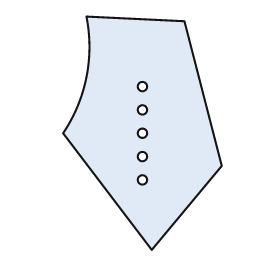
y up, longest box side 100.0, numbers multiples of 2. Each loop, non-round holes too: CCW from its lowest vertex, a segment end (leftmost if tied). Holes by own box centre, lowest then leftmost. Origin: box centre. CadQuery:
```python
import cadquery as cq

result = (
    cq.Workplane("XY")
    .moveTo(4.0, -50.0)
    .lineTo(34.0, -14.0)
    .lineTo(18.0, 48.0)
    .lineTo(-24.0, 50.0)
    .threePointArc((-24.0, 24.0), (-34.0, 0.0))
    .close()
    .moveTo(0.0, -20.0)
    .circle(2.0)
    .moveTo(0.0, -10.0)
    .circle(2.0)
    .moveTo(0.0, 0.0)
    .circle(2.0)
    .moveTo(0.0, 10.0)
    .circle(2.0)
    .moveTo(0.0, 20.0)
    .circle(2.0)
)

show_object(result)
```